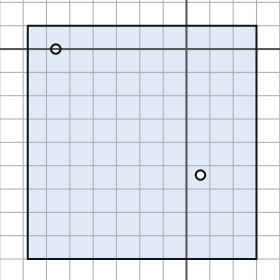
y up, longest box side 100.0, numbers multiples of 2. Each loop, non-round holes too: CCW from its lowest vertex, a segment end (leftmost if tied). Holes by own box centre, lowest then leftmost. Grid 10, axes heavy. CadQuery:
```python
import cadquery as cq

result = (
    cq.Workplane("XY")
    .moveTo(-68.0, -90.0)
    .lineTo(30.0, -90.0)
    .lineTo(30.0, 10.0)
    .lineTo(-68.0, 10.0)
    .close()
    .moveTo(6.0, -54.0)
    .circle(2.0)
    .moveTo(-56.0, 0.0)
    .circle(2.0)
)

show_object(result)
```